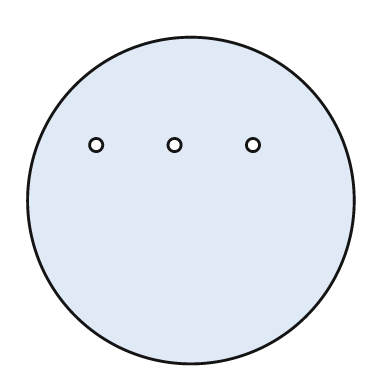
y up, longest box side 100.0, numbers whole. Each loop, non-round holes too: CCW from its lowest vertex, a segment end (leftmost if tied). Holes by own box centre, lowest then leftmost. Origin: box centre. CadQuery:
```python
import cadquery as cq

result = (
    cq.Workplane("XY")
    .moveTo(0.0, 0.0)
    .circle(50.0)
    .moveTo(-29.0, 17.0)
    .circle(2.0)
    .moveTo(-5.0, 17.0)
    .circle(2.0)
    .moveTo(19.0, 17.0)
    .circle(2.0)
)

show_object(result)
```